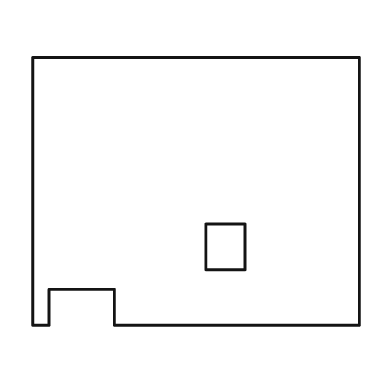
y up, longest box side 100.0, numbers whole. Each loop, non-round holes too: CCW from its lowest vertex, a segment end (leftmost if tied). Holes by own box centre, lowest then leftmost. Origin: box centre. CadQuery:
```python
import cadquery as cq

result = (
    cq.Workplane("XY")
    .moveTo(-50.0, -41.0)
    .lineTo(-45.0, -41.0)
    .lineTo(-45.0, -30.0)
    .lineTo(-25.0, -30.0)
    .lineTo(-25.0, -41.0)
    .lineTo(50.0, -41.0)
    .lineTo(50.0, 41.0)
    .lineTo(-50.0, 41.0)
    .close()
    .moveTo(3.0, -24.0)
    .lineTo(15.0, -24.0)
    .lineTo(15.0, -10.0)
    .lineTo(3.0, -10.0)
    .close()
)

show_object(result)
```